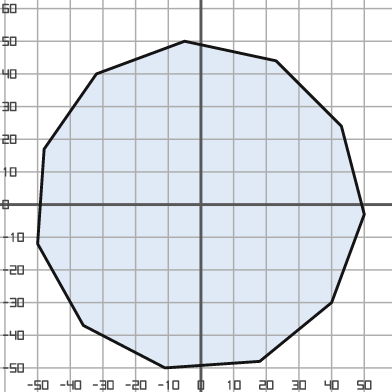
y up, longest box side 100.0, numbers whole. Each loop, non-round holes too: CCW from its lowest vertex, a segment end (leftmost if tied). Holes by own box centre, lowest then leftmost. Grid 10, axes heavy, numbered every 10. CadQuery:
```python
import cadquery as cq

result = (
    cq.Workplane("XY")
    .moveTo(-11.0, -50.0)
    .lineTo(18.0, -48.0)
    .lineTo(40.0, -30.0)
    .lineTo(50.0, -3.0)
    .lineTo(43.0, 24.0)
    .lineTo(23.0, 44.0)
    .lineTo(-5.0, 50.0)
    .lineTo(-32.0, 40.0)
    .lineTo(-48.0, 17.0)
    .lineTo(-50.0, -12.0)
    .lineTo(-36.0, -37.0)
    .close()
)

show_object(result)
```